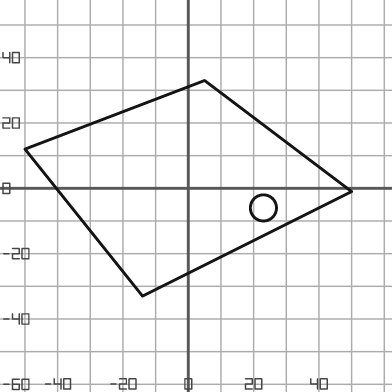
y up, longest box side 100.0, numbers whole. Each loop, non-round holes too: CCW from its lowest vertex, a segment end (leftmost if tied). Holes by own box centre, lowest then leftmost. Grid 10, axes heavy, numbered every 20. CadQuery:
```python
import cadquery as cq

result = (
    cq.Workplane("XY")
    .moveTo(-14.0, -33.0)
    .lineTo(50.0, -1.0)
    .lineTo(5.0, 33.0)
    .lineTo(-50.0, 12.0)
    .close()
    .moveTo(23.0, -6.0)
    .circle(4.0)
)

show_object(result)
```